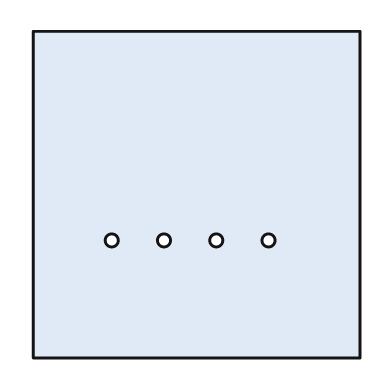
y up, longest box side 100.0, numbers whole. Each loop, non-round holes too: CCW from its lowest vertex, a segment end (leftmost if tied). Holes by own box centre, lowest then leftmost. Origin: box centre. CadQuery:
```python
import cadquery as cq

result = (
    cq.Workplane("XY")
    .moveTo(-50.0, -50.0)
    .lineTo(50.0, -50.0)
    .lineTo(50.0, 50.0)
    .lineTo(-50.0, 50.0)
    .close()
    .moveTo(-26.0, -14.0)
    .circle(2.0)
    .moveTo(-10.0, -14.0)
    .circle(2.0)
    .moveTo(6.0, -14.0)
    .circle(2.0)
    .moveTo(22.0, -14.0)
    .circle(2.0)
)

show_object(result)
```